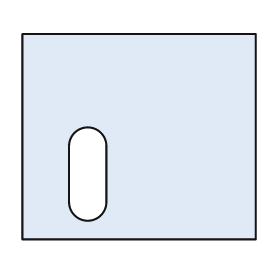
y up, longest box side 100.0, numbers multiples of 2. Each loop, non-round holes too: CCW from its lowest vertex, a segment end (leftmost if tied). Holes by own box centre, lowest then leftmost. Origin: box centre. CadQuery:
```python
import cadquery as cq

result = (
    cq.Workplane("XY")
    .moveTo(-50.0, -44.0)
    .lineTo(50.0, -44.0)
    .lineTo(50.0, 44.0)
    .lineTo(-50.0, 44.0)
    .close()
    .moveTo(-30.0, -28.0)
    .threePointArc((-22.0, -36.0), (-14.0, -28.0))
    .lineTo(-14.0, -4.0)
    .threePointArc((-22.0, 4.0), (-30.0, -4.0))
    .close()
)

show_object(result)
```